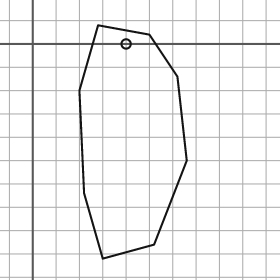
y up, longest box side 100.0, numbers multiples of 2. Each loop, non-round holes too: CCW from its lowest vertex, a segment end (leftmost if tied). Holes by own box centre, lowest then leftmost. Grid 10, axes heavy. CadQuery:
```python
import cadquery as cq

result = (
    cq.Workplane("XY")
    .moveTo(30.0, -92.0)
    .lineTo(52.0, -86.0)
    .lineTo(66.0, -50.0)
    .lineTo(62.0, -14.0)
    .lineTo(50.0, 4.0)
    .lineTo(28.0, 8.0)
    .lineTo(20.0, -20.0)
    .lineTo(22.0, -64.0)
    .close()
    .moveTo(40.0, 0.0)
    .circle(2.0)
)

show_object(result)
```